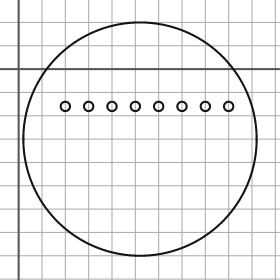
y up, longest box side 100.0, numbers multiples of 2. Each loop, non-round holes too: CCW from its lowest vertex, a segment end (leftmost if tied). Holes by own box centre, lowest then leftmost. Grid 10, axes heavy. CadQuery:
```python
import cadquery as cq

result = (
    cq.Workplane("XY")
    .moveTo(52.0, -30.0)
    .circle(50.0)
    .moveTo(20.0, -16.0)
    .circle(2.0)
    .moveTo(30.0, -16.0)
    .circle(2.0)
    .moveTo(40.0, -16.0)
    .circle(2.0)
    .moveTo(50.0, -16.0)
    .circle(2.0)
    .moveTo(60.0, -16.0)
    .circle(2.0)
    .moveTo(70.0, -16.0)
    .circle(2.0)
    .moveTo(80.0, -16.0)
    .circle(2.0)
    .moveTo(90.0, -16.0)
    .circle(2.0)
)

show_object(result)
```